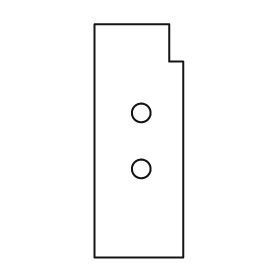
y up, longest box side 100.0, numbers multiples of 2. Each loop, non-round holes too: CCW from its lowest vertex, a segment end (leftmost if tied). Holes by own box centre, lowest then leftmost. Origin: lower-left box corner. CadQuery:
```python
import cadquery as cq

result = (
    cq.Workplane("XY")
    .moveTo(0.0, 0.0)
    .lineTo(38.0, 0.0)
    .lineTo(38.0, 84.0)
    .lineTo(32.0, 84.0)
    .lineTo(32.0, 100.0)
    .lineTo(0.0, 100.0)
    .close()
    .moveTo(20.0, 38.0)
    .circle(4.0)
    .moveTo(20.0, 62.0)
    .circle(4.0)
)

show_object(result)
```